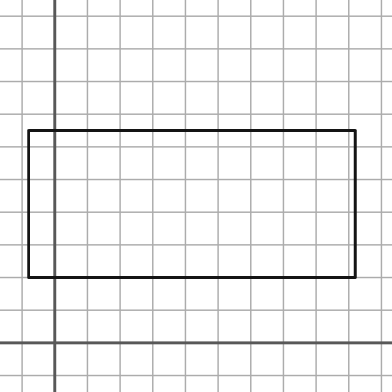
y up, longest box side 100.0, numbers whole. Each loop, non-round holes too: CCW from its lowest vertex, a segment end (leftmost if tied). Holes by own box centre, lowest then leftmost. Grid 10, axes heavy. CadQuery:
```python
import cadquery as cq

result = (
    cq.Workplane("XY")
    .moveTo(-8.0, 20.0)
    .lineTo(92.0, 20.0)
    .lineTo(92.0, 65.0)
    .lineTo(-8.0, 65.0)
    .close()
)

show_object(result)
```